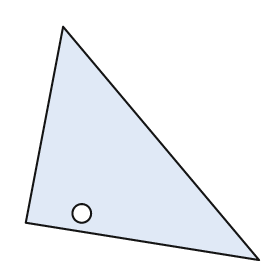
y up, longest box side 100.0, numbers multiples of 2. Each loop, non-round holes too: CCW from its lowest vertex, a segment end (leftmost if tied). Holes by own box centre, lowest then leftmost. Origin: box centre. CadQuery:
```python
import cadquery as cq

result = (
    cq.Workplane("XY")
    .moveTo(50.0, -50.0)
    .lineTo(-34.0, 50.0)
    .lineTo(-50.0, -34.0)
    .close()
    .moveTo(-26.0, -30.0)
    .circle(4.0)
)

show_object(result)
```